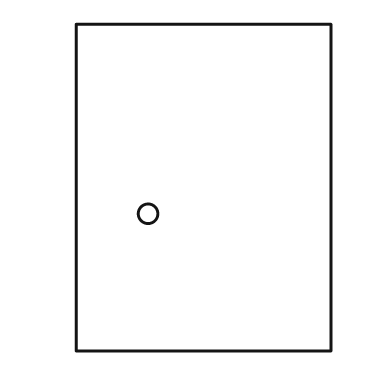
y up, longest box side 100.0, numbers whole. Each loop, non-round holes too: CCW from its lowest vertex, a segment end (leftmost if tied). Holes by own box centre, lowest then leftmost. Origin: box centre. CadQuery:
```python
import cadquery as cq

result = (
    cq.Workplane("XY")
    .moveTo(-39.0, -50.0)
    .lineTo(39.0, -50.0)
    .lineTo(39.0, 50.0)
    .lineTo(-39.0, 50.0)
    .close()
    .moveTo(-17.0, -8.0)
    .circle(3.0)
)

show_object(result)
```